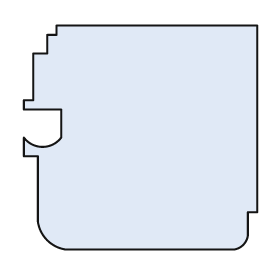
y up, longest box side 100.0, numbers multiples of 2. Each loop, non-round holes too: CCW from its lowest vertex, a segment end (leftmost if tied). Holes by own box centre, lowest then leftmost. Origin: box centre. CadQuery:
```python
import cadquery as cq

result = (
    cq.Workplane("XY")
    .moveTo(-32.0, -48.0)
    .lineTo(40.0, -48.0)
    .threePointArc((44.0, -46.0), (46.0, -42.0))
    .lineTo(46.0, -32.0)
    .lineTo(50.0, -32.0)
    .lineTo(50.0, 48.0)
    .lineTo(-36.0, 48.0)
    .lineTo(-36.0, 44.0)
    .lineTo(-40.0, 44.0)
    .lineTo(-40.0, 36.0)
    .lineTo(-46.0, 36.0)
    .lineTo(-46.0, 16.0)
    .lineTo(-50.0, 16.0)
    .lineTo(-50.0, 12.0)
    .lineTo(-34.0, 12.0)
    .lineTo(-34.0, 0.0)
    .threePointArc((-42.0, -4.0), (-50.0, 0.0))
    .lineTo(-50.0, -8.0)
    .lineTo(-44.0, -8.0)
    .lineTo(-44.0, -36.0)
    .threePointArc((-40.0, -44.0), (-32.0, -48.0))
    .close()
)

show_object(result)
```